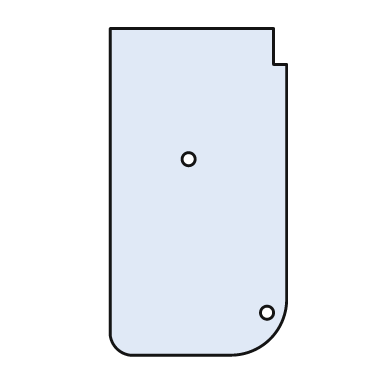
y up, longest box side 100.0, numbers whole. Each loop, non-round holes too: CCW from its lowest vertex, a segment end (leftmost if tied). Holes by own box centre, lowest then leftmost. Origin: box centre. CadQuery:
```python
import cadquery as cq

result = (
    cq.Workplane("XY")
    .moveTo(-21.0, -50.0)
    .lineTo(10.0, -50.0)
    .threePointArc((22.0, -45.0), (27.0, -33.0))
    .lineTo(27.0, 39.0)
    .lineTo(23.0, 39.0)
    .lineTo(23.0, 50.0)
    .lineTo(-27.0, 50.0)
    .lineTo(-27.0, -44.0)
    .threePointArc((-25.0, -48.0), (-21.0, -50.0))
    .close()
    .moveTo(21.0, -37.0)
    .circle(2.0)
    .moveTo(-3.0, 10.0)
    .circle(2.0)
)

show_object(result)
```